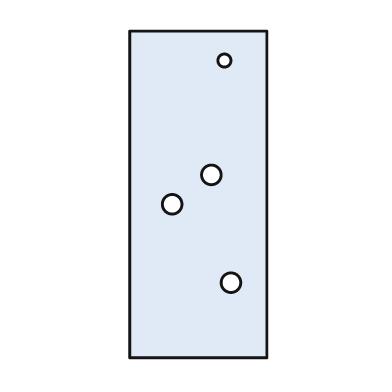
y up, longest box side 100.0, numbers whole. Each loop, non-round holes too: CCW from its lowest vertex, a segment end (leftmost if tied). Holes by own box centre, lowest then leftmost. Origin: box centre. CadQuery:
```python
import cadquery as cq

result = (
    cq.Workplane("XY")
    .moveTo(-21.0, -50.0)
    .lineTo(21.0, -50.0)
    .lineTo(21.0, 50.0)
    .lineTo(-21.0, 50.0)
    .close()
    .moveTo(10.0, -27.0)
    .circle(3.0)
    .moveTo(-8.0, -3.0)
    .circle(3.0)
    .moveTo(4.0, 6.0)
    .circle(3.0)
    .moveTo(8.0, 41.0)
    .circle(2.0)
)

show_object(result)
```